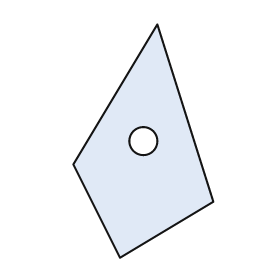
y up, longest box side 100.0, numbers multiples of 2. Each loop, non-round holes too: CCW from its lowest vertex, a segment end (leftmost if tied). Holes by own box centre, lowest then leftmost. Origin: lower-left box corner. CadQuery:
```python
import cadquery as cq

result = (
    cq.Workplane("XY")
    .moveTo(20.0, 0.0)
    .lineTo(60.0, 24.0)
    .lineTo(36.0, 100.0)
    .lineTo(0.0, 40.0)
    .close()
    .moveTo(30.0, 50.0)
    .circle(6.0)
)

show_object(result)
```